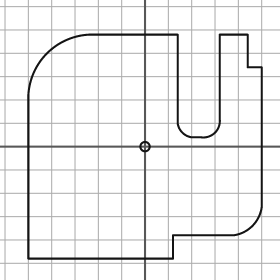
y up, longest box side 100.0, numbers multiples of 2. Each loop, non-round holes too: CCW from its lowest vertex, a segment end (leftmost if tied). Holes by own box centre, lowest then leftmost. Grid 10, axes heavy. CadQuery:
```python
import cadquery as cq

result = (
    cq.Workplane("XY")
    .moveTo(-50.0, -48.0)
    .lineTo(12.0, -48.0)
    .lineTo(12.0, -38.0)
    .lineTo(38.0, -38.0)
    .threePointArc((46.0, -34.0), (50.0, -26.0))
    .lineTo(50.0, 34.0)
    .lineTo(44.0, 34.0)
    .lineTo(44.0, 48.0)
    .lineTo(32.0, 48.0)
    .lineTo(32.0, 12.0)
    .threePointArc((30.0, 6.0), (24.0, 4.0))
    .lineTo(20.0, 4.0)
    .threePointArc((16.0, 6.0), (14.0, 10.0))
    .lineTo(14.0, 48.0)
    .lineTo(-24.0, 48.0)
    .threePointArc((-42.0, 40.0), (-50.0, 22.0))
    .close()
    .moveTo(0.0, 0.0)
    .circle(2.0)
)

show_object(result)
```